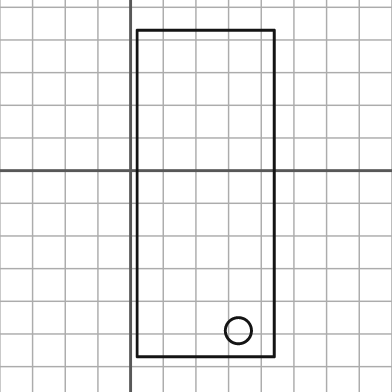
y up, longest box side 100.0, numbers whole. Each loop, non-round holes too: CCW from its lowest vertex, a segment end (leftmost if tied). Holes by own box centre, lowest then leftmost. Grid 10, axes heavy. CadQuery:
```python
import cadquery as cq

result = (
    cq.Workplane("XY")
    .moveTo(2.0, -57.0)
    .lineTo(44.0, -57.0)
    .lineTo(44.0, 43.0)
    .lineTo(2.0, 43.0)
    .close()
    .moveTo(33.0, -49.0)
    .circle(4.0)
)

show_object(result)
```